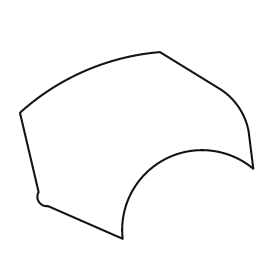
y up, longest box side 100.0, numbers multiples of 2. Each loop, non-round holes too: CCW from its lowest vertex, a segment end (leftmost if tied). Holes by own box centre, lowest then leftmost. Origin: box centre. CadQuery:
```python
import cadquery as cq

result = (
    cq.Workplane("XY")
    .moveTo(-6.0, -40.0)
    .threePointArc((12.0, -6.0), (50.0, -10.0))
    .lineTo(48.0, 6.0)
    .threePointArc((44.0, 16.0), (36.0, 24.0))
    .lineTo(10.0, 40.0)
    .threePointArc((-22.0, 32.0), (-50.0, 14.0))
    .lineTo(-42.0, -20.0)
    .threePointArc((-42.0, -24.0), (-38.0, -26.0))
    .close()
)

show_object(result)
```